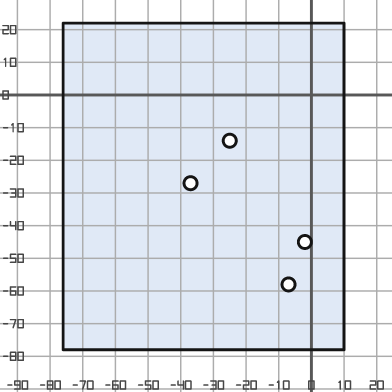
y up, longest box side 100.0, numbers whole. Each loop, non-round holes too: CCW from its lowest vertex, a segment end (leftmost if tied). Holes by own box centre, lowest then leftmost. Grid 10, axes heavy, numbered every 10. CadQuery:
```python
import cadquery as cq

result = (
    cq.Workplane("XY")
    .moveTo(-76.0, -78.0)
    .lineTo(10.0, -78.0)
    .lineTo(10.0, 22.0)
    .lineTo(-76.0, 22.0)
    .close()
    .moveTo(-7.0, -58.0)
    .circle(2.0)
    .moveTo(-2.0, -45.0)
    .circle(2.0)
    .moveTo(-37.0, -27.0)
    .circle(2.0)
    .moveTo(-25.0, -14.0)
    .circle(2.0)
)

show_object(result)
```